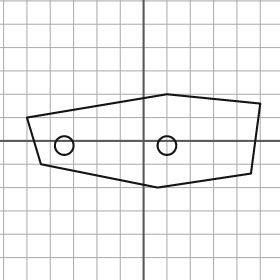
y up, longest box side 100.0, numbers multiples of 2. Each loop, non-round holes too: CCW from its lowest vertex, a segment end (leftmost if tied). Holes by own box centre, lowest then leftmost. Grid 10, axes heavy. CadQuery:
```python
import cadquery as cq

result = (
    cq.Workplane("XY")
    .moveTo(6.0, -20.0)
    .lineTo(46.0, -14.0)
    .lineTo(50.0, 16.0)
    .lineTo(10.0, 20.0)
    .lineTo(-50.0, 10.0)
    .lineTo(-44.0, -10.0)
    .close()
    .moveTo(-34.0, -2.0)
    .circle(4.0)
    .moveTo(10.0, -2.0)
    .circle(4.0)
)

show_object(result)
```